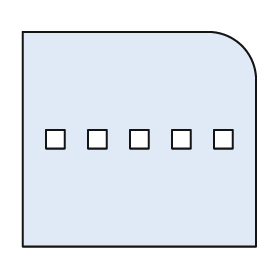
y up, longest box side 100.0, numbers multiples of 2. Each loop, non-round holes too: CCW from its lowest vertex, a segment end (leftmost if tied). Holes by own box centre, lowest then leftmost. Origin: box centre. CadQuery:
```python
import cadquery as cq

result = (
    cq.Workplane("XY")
    .moveTo(-50.0, -46.0)
    .lineTo(50.0, -46.0)
    .lineTo(50.0, 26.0)
    .threePointArc((44.0, 40.0), (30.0, 46.0))
    .lineTo(-50.0, 46.0)
    .close()
    .moveTo(-40.0, -4.0)
    .lineTo(-32.0, -4.0)
    .lineTo(-32.0, 4.0)
    .lineTo(-40.0, 4.0)
    .close()
    .moveTo(-22.0, -4.0)
    .lineTo(-14.0, -4.0)
    .lineTo(-14.0, 4.0)
    .lineTo(-22.0, 4.0)
    .close()
    .moveTo(-4.0, -4.0)
    .lineTo(4.0, -4.0)
    .lineTo(4.0, 4.0)
    .lineTo(-4.0, 4.0)
    .close()
    .moveTo(14.0, -4.0)
    .lineTo(22.0, -4.0)
    .lineTo(22.0, 4.0)
    .lineTo(14.0, 4.0)
    .close()
    .moveTo(32.0, -4.0)
    .lineTo(40.0, -4.0)
    .lineTo(40.0, 4.0)
    .lineTo(32.0, 4.0)
    .close()
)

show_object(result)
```